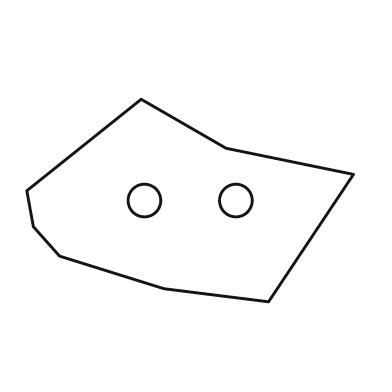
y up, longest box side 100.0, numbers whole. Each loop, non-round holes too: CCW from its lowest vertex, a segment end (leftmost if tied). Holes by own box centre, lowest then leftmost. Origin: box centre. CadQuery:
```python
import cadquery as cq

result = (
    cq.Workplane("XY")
    .moveTo(24.0, -31.0)
    .lineTo(50.0, 8.0)
    .lineTo(11.0, 16.0)
    .lineTo(-15.0, 31.0)
    .lineTo(-50.0, 3.0)
    .lineTo(-48.0, -8.0)
    .lineTo(-40.0, -17.0)
    .lineTo(-8.0, -27.0)
    .close()
    .moveTo(-14.0, 0.0)
    .circle(5.0)
    .moveTo(14.0, 0.0)
    .circle(5.0)
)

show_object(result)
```